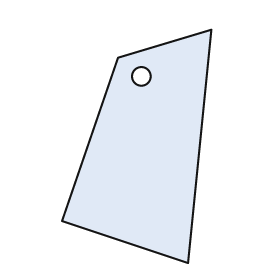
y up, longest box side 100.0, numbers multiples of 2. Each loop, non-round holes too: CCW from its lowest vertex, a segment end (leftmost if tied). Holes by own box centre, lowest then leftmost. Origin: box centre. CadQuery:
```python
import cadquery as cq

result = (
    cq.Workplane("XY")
    .moveTo(22.0, -50.0)
    .lineTo(32.0, 50.0)
    .lineTo(-8.0, 38.0)
    .lineTo(-32.0, -32.0)
    .close()
    .moveTo(2.0, 30.0)
    .circle(4.0)
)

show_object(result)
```